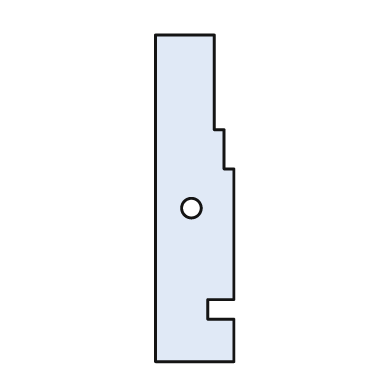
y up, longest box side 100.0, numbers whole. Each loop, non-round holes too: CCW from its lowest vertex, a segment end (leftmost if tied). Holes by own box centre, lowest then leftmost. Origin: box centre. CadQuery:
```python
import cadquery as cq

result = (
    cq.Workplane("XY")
    .moveTo(-12.0, -50.0)
    .lineTo(12.0, -50.0)
    .lineTo(12.0, -37.0)
    .lineTo(4.0, -37.0)
    .lineTo(4.0, -31.0)
    .lineTo(12.0, -31.0)
    .lineTo(12.0, 9.0)
    .lineTo(9.0, 9.0)
    .lineTo(9.0, 21.0)
    .lineTo(6.0, 21.0)
    .lineTo(6.0, 50.0)
    .lineTo(-12.0, 50.0)
    .close()
    .moveTo(-1.0, -3.0)
    .circle(3.0)
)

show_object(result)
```